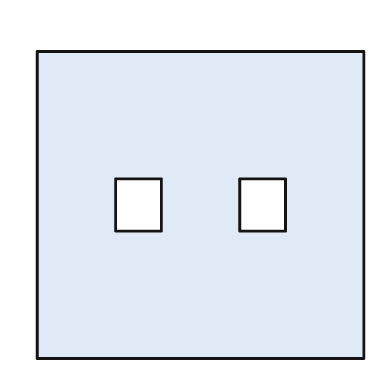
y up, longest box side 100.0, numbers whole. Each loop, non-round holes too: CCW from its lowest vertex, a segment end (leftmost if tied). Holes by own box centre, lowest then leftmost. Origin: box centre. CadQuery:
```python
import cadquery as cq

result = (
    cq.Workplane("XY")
    .moveTo(-50.0, -47.0)
    .lineTo(50.0, -47.0)
    .lineTo(50.0, 47.0)
    .lineTo(-50.0, 47.0)
    .close()
    .moveTo(-26.0, -8.0)
    .lineTo(-12.0, -8.0)
    .lineTo(-12.0, 8.0)
    .lineTo(-26.0, 8.0)
    .close()
    .moveTo(12.0, -8.0)
    .lineTo(26.0, -8.0)
    .lineTo(26.0, 8.0)
    .lineTo(12.0, 8.0)
    .close()
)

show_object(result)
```